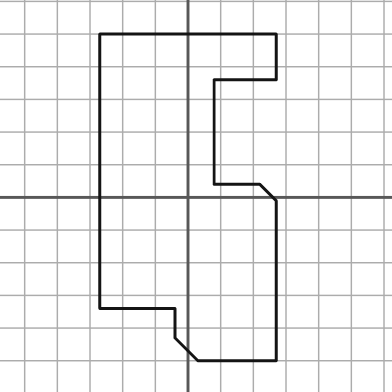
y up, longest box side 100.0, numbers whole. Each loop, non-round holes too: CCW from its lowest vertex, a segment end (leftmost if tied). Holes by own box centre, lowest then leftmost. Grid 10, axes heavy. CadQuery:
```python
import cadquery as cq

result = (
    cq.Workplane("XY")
    .moveTo(3.0, -50.0)
    .lineTo(27.0, -50.0)
    .lineTo(27.0, -1.0)
    .lineTo(22.0, 4.0)
    .lineTo(8.0, 4.0)
    .lineTo(8.0, 36.0)
    .lineTo(27.0, 36.0)
    .lineTo(27.0, 50.0)
    .lineTo(-27.0, 50.0)
    .lineTo(-27.0, -34.0)
    .lineTo(-4.0, -34.0)
    .lineTo(-4.0, -43.0)
    .close()
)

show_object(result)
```